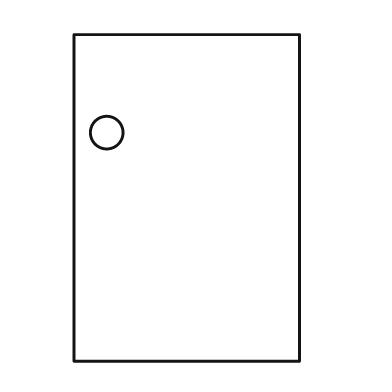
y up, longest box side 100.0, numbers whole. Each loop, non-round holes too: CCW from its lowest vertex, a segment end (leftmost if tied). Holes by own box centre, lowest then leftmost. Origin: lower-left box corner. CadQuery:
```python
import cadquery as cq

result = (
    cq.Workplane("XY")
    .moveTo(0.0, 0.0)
    .lineTo(69.0, 0.0)
    .lineTo(69.0, 100.0)
    .lineTo(0.0, 100.0)
    .close()
    .moveTo(10.0, 70.0)
    .circle(5.0)
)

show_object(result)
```